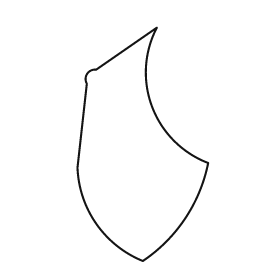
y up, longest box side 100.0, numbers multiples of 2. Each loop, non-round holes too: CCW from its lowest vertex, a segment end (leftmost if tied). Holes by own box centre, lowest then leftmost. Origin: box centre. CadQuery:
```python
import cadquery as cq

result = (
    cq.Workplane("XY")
    .moveTo(0.0, -50.0)
    .threePointArc((18.0, -32.0), (28.0, -8.0))
    .threePointArc((4.0, 16.0), (6.0, 50.0))
    .lineTo(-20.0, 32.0)
    .threePointArc((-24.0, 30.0), (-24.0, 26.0))
    .lineTo(-28.0, -10.0)
    .threePointArc((-20.0, -34.0), (0.0, -50.0))
    .close()
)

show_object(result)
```